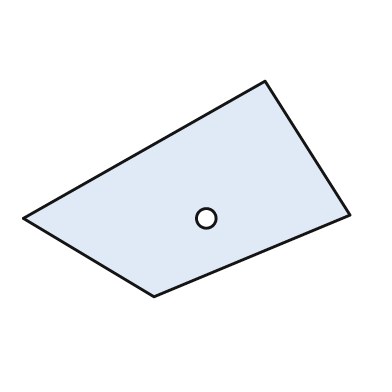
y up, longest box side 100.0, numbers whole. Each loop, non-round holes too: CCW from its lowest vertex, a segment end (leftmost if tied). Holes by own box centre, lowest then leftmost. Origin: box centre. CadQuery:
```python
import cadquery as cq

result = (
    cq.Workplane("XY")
    .moveTo(-10.0, -33.0)
    .lineTo(50.0, -8.0)
    .lineTo(24.0, 33.0)
    .lineTo(-50.0, -9.0)
    .close()
    .moveTo(6.0, -9.0)
    .circle(3.0)
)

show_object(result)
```